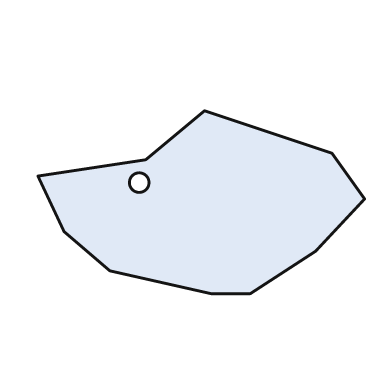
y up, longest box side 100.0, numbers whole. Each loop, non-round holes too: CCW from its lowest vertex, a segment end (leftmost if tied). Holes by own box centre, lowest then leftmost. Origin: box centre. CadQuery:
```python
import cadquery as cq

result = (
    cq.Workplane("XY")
    .moveTo(3.0, -28.0)
    .lineTo(15.0, -28.0)
    .lineTo(35.0, -15.0)
    .lineTo(50.0, 1.0)
    .lineTo(40.0, 15.0)
    .lineTo(1.0, 28.0)
    .lineTo(-17.0, 13.0)
    .lineTo(-50.0, 8.0)
    .lineTo(-42.0, -9.0)
    .lineTo(-28.0, -21.0)
    .close()
    .moveTo(-19.0, 6.0)
    .circle(3.0)
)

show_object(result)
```